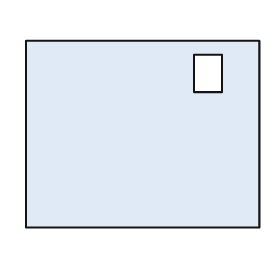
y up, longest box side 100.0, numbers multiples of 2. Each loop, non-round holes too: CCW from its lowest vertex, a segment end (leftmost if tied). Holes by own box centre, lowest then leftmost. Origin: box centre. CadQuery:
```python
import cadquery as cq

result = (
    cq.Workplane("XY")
    .moveTo(-50.0, -40.0)
    .lineTo(50.0, -40.0)
    .lineTo(50.0, 40.0)
    .lineTo(-50.0, 40.0)
    .close()
    .moveTo(22.0, 18.0)
    .lineTo(34.0, 18.0)
    .lineTo(34.0, 34.0)
    .lineTo(22.0, 34.0)
    .close()
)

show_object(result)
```